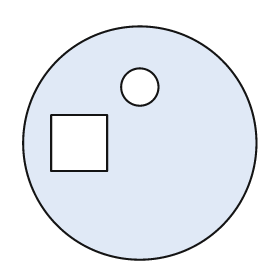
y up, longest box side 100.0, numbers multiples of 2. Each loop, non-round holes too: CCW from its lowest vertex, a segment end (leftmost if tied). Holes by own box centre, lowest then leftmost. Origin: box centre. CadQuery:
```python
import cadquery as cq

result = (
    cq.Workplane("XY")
    .moveTo(0.0, 0.0)
    .circle(50.0)
    .moveTo(-38.0, -12.0)
    .lineTo(-14.0, -12.0)
    .lineTo(-14.0, 12.0)
    .lineTo(-38.0, 12.0)
    .close()
    .moveTo(0.0, 24.0)
    .circle(8.0)
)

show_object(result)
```